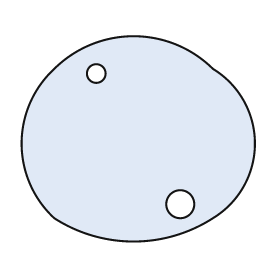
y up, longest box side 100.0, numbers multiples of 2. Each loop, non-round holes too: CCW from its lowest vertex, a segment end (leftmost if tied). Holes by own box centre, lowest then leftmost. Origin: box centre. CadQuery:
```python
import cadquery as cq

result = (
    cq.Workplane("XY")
    .moveTo(-36.0, -34.0)
    .threePointArc((-2.0, -44.0), (32.0, -34.0))
    .threePointArc((50.0, -2.0), (32.0, 30.0))
    .threePointArc((-2.0, 44.0), (-36.0, 30.0))
    .threePointArc((-50.0, -2.0), (-36.0, -34.0))
    .close()
    .moveTo(18.0, -28.0)
    .circle(6.0)
    .moveTo(-18.0, 28.0)
    .circle(4.0)
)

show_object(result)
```